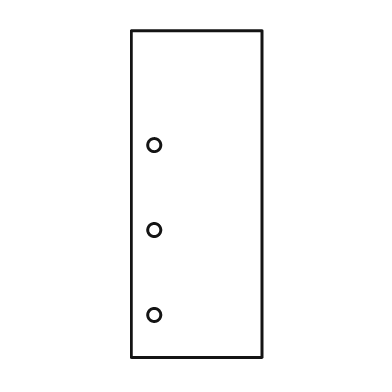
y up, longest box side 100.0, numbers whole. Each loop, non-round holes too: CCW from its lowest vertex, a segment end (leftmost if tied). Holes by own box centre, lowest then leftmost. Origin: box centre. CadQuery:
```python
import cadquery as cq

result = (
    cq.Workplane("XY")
    .moveTo(-20.0, -50.0)
    .lineTo(20.0, -50.0)
    .lineTo(20.0, 50.0)
    .lineTo(-20.0, 50.0)
    .close()
    .moveTo(-13.0, -37.0)
    .circle(2.0)
    .moveTo(-13.0, -11.0)
    .circle(2.0)
    .moveTo(-13.0, 15.0)
    .circle(2.0)
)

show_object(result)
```